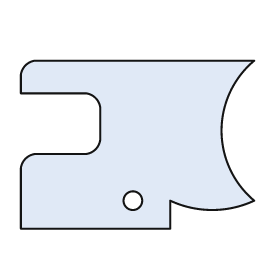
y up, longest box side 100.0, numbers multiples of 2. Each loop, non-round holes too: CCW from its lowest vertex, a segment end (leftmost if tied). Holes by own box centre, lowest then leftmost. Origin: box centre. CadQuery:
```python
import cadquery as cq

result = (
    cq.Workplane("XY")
    .moveTo(-50.0, -36.0)
    .lineTo(14.0, -36.0)
    .lineTo(14.0, -24.0)
    .threePointArc((32.0, -28.0), (50.0, -24.0))
    .threePointArc((36.0, 6.0), (50.0, 36.0))
    .lineTo(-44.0, 36.0)
    .threePointArc((-48.0, 34.0), (-50.0, 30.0))
    .lineTo(-50.0, 22.0)
    .lineTo(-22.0, 22.0)
    .threePointArc((-18.0, 20.0), (-16.0, 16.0))
    .lineTo(-16.0, 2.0)
    .threePointArc((-18.0, -2.0), (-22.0, -4.0))
    .lineTo(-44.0, -4.0)
    .threePointArc((-48.0, -6.0), (-50.0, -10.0))
    .close()
    .moveTo(-2.0, -24.0)
    .circle(4.0)
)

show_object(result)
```